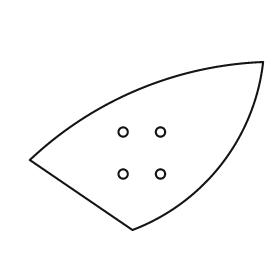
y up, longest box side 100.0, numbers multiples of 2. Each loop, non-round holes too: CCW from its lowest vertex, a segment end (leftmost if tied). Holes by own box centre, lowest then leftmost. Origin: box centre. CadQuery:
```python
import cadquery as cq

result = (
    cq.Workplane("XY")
    .moveTo(-6.0, -36.0)
    .threePointArc((32.0, -8.0), (50.0, 36.0))
    .threePointArc((-4.0, 24.0), (-50.0, -6.0))
    .close()
    .moveTo(-10.0, -12.0)
    .circle(2.0)
    .moveTo(6.0, -12.0)
    .circle(2.0)
    .moveTo(-10.0, 6.0)
    .circle(2.0)
    .moveTo(6.0, 6.0)
    .circle(2.0)
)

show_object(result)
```